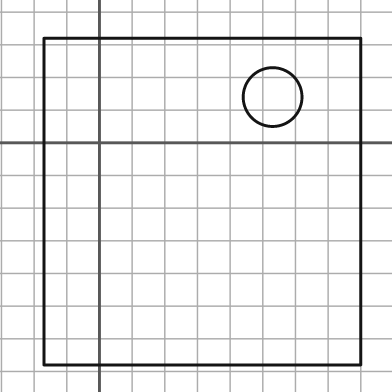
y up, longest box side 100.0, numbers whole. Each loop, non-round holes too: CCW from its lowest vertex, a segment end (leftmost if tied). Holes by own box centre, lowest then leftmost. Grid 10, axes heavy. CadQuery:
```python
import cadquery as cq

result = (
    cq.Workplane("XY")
    .moveTo(-17.0, -68.0)
    .lineTo(80.0, -68.0)
    .lineTo(80.0, 32.0)
    .lineTo(-17.0, 32.0)
    .close()
    .moveTo(53.0, 14.0)
    .circle(9.0)
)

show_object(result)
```